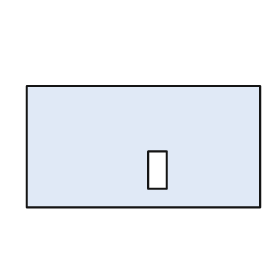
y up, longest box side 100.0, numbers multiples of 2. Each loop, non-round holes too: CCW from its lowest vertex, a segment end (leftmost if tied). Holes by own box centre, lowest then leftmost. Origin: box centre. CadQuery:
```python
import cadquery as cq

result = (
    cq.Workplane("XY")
    .moveTo(-50.0, -26.0)
    .lineTo(50.0, -26.0)
    .lineTo(50.0, 26.0)
    .lineTo(-50.0, 26.0)
    .close()
    .moveTo(2.0, -18.0)
    .lineTo(10.0, -18.0)
    .lineTo(10.0, -2.0)
    .lineTo(2.0, -2.0)
    .close()
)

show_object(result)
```